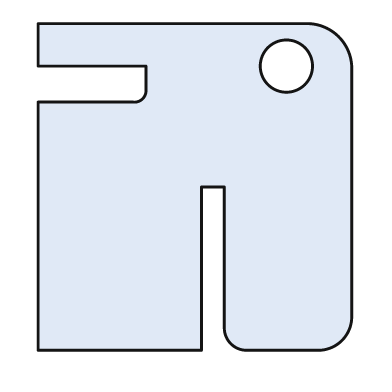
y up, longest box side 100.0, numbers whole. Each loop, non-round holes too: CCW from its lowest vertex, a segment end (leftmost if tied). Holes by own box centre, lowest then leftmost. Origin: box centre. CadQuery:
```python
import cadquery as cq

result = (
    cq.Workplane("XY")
    .moveTo(-48.0, -50.0)
    .lineTo(2.0, -50.0)
    .lineTo(2.0, 0.0)
    .lineTo(9.0, 0.0)
    .lineTo(9.0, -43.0)
    .threePointArc((11.0, -48.0), (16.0, -50.0))
    .lineTo(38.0, -50.0)
    .threePointArc((45.0, -47.0), (48.0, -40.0))
    .lineTo(48.0, 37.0)
    .threePointArc((44.0, 46.0), (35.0, 50.0))
    .lineTo(-48.0, 50.0)
    .lineTo(-48.0, 37.0)
    .lineTo(-15.0, 37.0)
    .lineTo(-15.0, 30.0)
    .threePointArc((-16.0, 27.0), (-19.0, 26.0))
    .lineTo(-48.0, 26.0)
    .close()
    .moveTo(28.0, 37.0)
    .circle(8.0)
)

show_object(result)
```